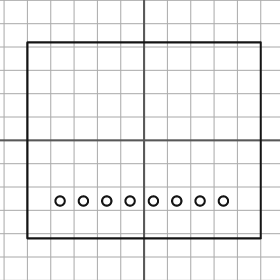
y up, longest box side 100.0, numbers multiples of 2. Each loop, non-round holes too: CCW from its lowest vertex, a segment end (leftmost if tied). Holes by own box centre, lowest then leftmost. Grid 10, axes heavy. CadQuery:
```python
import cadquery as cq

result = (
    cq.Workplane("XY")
    .moveTo(-50.0, -42.0)
    .lineTo(50.0, -42.0)
    .lineTo(50.0, 42.0)
    .lineTo(-50.0, 42.0)
    .close()
    .moveTo(-36.0, -26.0)
    .circle(2.0)
    .moveTo(-26.0, -26.0)
    .circle(2.0)
    .moveTo(-16.0, -26.0)
    .circle(2.0)
    .moveTo(-6.0, -26.0)
    .circle(2.0)
    .moveTo(4.0, -26.0)
    .circle(2.0)
    .moveTo(14.0, -26.0)
    .circle(2.0)
    .moveTo(24.0, -26.0)
    .circle(2.0)
    .moveTo(34.0, -26.0)
    .circle(2.0)
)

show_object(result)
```